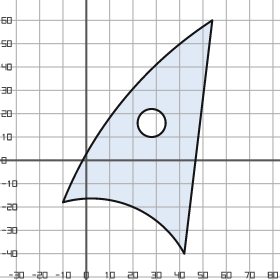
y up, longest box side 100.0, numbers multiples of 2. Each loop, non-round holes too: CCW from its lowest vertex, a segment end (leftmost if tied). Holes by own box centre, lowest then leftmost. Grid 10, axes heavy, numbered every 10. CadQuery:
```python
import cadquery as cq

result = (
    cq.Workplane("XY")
    .moveTo(42.0, -40.0)
    .lineTo(54.0, 60.0)
    .threePointArc((16.0, 26.0), (-10.0, -18.0))
    .threePointArc((20.0, -20.0), (42.0, -40.0))
    .close()
    .moveTo(28.0, 16.0)
    .circle(6.0)
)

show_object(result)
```